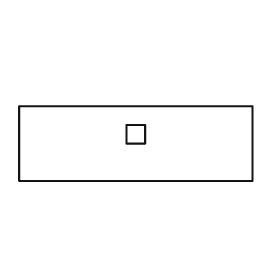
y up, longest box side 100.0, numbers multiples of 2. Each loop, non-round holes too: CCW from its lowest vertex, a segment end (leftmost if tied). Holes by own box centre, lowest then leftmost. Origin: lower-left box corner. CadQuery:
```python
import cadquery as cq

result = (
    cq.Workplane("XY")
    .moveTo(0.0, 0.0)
    .lineTo(100.0, 0.0)
    .lineTo(100.0, 32.0)
    .lineTo(0.0, 32.0)
    .close()
    .moveTo(46.0, 16.0)
    .lineTo(54.0, 16.0)
    .lineTo(54.0, 24.0)
    .lineTo(46.0, 24.0)
    .close()
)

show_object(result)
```